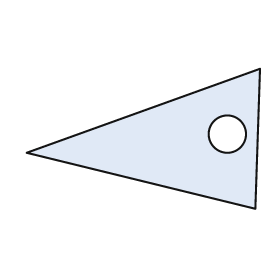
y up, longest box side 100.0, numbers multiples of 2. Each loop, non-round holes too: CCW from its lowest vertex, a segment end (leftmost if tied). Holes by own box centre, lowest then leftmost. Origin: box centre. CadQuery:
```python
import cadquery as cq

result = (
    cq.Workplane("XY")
    .moveTo(48.0, -30.0)
    .lineTo(50.0, 30.0)
    .lineTo(-50.0, -6.0)
    .close()
    .moveTo(36.0, 2.0)
    .circle(8.0)
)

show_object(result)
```